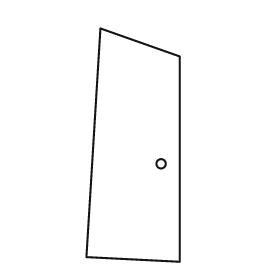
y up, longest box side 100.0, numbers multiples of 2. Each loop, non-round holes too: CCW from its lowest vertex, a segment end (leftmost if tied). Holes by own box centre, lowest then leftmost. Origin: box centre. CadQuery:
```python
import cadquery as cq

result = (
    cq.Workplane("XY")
    .moveTo(20.0, -50.0)
    .lineTo(20.0, 38.0)
    .lineTo(-14.0, 50.0)
    .lineTo(-20.0, -48.0)
    .close()
    .moveTo(12.0, -8.0)
    .circle(2.0)
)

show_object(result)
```